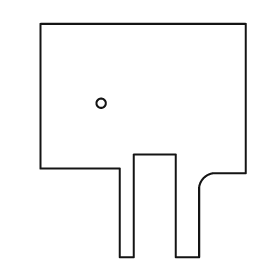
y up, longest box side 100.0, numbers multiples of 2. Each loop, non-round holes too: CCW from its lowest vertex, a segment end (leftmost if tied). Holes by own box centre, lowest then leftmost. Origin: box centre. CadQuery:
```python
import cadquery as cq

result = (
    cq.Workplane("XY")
    .moveTo(-10.0, -50.0)
    .lineTo(-4.0, -50.0)
    .lineTo(-4.0, -6.0)
    .lineTo(14.0, -6.0)
    .lineTo(14.0, -50.0)
    .lineTo(24.0, -50.0)
    .lineTo(24.0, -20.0)
    .threePointArc((26.0, -16.0), (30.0, -14.0))
    .lineTo(44.0, -14.0)
    .lineTo(44.0, 50.0)
    .lineTo(-44.0, 50.0)
    .lineTo(-44.0, -12.0)
    .lineTo(-10.0, -12.0)
    .close()
    .moveTo(-18.0, 16.0)
    .circle(2.0)
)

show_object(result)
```